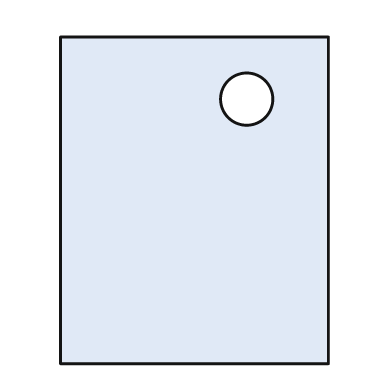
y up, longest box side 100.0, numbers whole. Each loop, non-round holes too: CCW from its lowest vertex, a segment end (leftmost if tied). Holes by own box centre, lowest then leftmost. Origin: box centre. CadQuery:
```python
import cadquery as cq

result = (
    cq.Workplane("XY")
    .moveTo(-41.0, -50.0)
    .lineTo(41.0, -50.0)
    .lineTo(41.0, 50.0)
    .lineTo(-41.0, 50.0)
    .close()
    .moveTo(16.0, 31.0)
    .circle(8.0)
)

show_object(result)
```